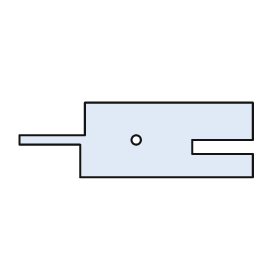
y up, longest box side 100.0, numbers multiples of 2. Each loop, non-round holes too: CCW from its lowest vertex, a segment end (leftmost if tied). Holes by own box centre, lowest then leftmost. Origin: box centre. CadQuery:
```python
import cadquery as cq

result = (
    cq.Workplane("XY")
    .moveTo(-24.0, -16.0)
    .lineTo(50.0, -16.0)
    .lineTo(50.0, -6.0)
    .lineTo(24.0, -6.0)
    .lineTo(24.0, 0.0)
    .lineTo(50.0, 0.0)
    .lineTo(50.0, 16.0)
    .lineTo(-22.0, 16.0)
    .lineTo(-22.0, 2.0)
    .lineTo(-50.0, 2.0)
    .lineTo(-50.0, -2.0)
    .lineTo(-24.0, -2.0)
    .close()
    .moveTo(0.0, 0.0)
    .circle(2.0)
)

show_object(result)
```